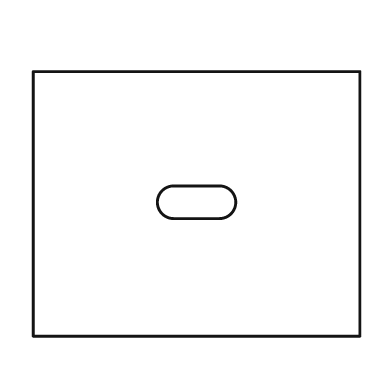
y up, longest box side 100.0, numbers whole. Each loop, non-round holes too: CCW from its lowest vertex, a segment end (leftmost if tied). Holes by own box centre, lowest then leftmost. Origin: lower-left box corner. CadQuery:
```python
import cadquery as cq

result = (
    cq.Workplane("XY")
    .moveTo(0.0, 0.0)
    .lineTo(100.0, 0.0)
    .lineTo(100.0, 81.0)
    .lineTo(0.0, 81.0)
    .close()
    .moveTo(43.0, 36.0)
    .lineTo(57.0, 36.0)
    .threePointArc((62.0, 41.0), (57.0, 46.0))
    .lineTo(43.0, 46.0)
    .threePointArc((38.0, 41.0), (43.0, 36.0))
    .close()
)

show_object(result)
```